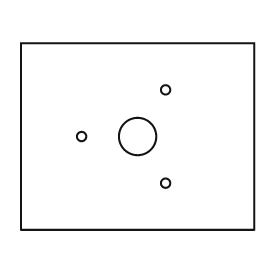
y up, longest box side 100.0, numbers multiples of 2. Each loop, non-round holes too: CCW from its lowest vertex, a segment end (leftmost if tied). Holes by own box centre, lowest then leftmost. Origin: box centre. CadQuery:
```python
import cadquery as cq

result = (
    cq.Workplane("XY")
    .moveTo(-50.0, -40.0)
    .lineTo(50.0, -40.0)
    .lineTo(50.0, 40.0)
    .lineTo(-50.0, 40.0)
    .close()
    .moveTo(12.0, -20.0)
    .circle(2.0)
    .moveTo(-24.0, 0.0)
    .circle(2.0)
    .moveTo(0.0, 0.0)
    .circle(8.0)
    .moveTo(12.0, 20.0)
    .circle(2.0)
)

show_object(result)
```